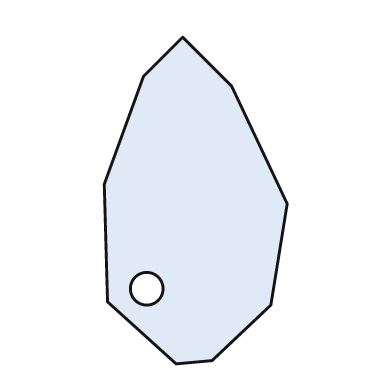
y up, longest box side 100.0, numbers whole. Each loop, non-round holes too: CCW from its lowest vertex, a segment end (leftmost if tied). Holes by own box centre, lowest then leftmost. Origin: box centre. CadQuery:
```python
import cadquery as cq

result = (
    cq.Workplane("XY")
    .moveTo(-6.0, -50.0)
    .lineTo(5.0, -49.0)
    .lineTo(23.0, -32.0)
    .lineTo(28.0, -1.0)
    .lineTo(11.0, 35.0)
    .lineTo(-4.0, 50.0)
    .lineTo(-16.0, 38.0)
    .lineTo(-28.0, 5.0)
    .lineTo(-27.0, -31.0)
    .close()
    .moveTo(-15.0, -27.0)
    .circle(5.0)
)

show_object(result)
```